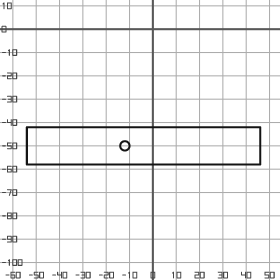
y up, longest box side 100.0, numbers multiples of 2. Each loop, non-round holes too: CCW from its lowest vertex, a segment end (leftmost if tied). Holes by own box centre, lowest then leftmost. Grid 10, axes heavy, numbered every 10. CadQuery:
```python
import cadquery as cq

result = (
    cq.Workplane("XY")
    .moveTo(-54.0, -58.0)
    .lineTo(46.0, -58.0)
    .lineTo(46.0, -42.0)
    .lineTo(-54.0, -42.0)
    .close()
    .moveTo(-12.0, -50.0)
    .circle(2.0)
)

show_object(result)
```